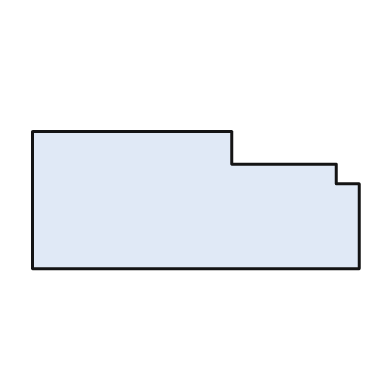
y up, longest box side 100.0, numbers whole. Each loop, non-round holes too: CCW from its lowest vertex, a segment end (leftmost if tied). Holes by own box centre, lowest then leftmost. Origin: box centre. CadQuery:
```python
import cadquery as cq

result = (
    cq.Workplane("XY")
    .moveTo(-50.0, -21.0)
    .lineTo(50.0, -21.0)
    .lineTo(50.0, 5.0)
    .lineTo(43.0, 5.0)
    .lineTo(43.0, 11.0)
    .lineTo(11.0, 11.0)
    .lineTo(11.0, 21.0)
    .lineTo(-50.0, 21.0)
    .close()
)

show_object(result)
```